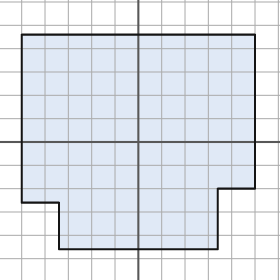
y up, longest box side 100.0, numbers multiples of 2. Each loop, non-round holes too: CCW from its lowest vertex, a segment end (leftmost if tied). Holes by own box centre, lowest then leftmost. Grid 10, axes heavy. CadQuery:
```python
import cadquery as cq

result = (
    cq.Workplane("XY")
    .moveTo(-34.0, -46.0)
    .lineTo(34.0, -46.0)
    .lineTo(34.0, -20.0)
    .lineTo(50.0, -20.0)
    .lineTo(50.0, 46.0)
    .lineTo(-50.0, 46.0)
    .lineTo(-50.0, -26.0)
    .lineTo(-34.0, -26.0)
    .close()
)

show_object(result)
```